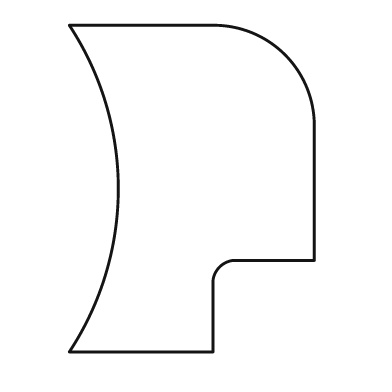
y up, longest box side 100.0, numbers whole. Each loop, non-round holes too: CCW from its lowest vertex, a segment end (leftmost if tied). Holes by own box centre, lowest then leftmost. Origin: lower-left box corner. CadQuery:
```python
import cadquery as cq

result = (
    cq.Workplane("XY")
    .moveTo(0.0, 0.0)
    .lineTo(44.0, 0.0)
    .lineTo(44.0, 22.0)
    .threePointArc((46.0, 26.0), (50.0, 28.0))
    .lineTo(75.0, 28.0)
    .lineTo(75.0, 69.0)
    .threePointArc((66.0, 91.0), (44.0, 100.0))
    .lineTo(0.0, 100.0)
    .threePointArc((15.0, 50.0), (0.0, 0.0))
    .close()
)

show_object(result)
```